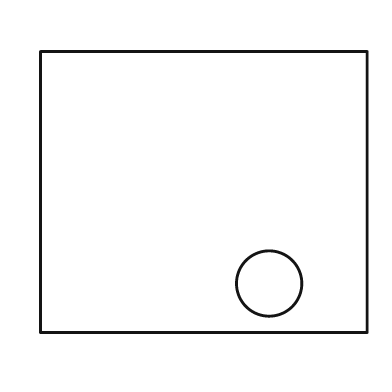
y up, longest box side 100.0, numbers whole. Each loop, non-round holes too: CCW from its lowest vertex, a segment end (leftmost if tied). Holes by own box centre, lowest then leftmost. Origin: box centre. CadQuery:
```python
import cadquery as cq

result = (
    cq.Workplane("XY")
    .moveTo(-50.0, -43.0)
    .lineTo(50.0, -43.0)
    .lineTo(50.0, 43.0)
    .lineTo(-50.0, 43.0)
    .close()
    .moveTo(20.0, -28.0)
    .circle(10.0)
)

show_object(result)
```